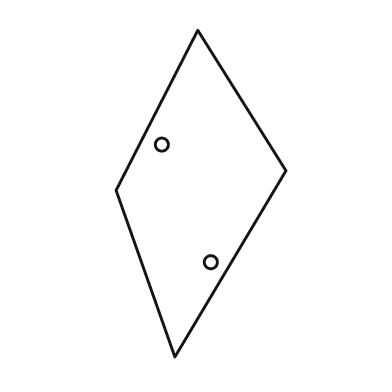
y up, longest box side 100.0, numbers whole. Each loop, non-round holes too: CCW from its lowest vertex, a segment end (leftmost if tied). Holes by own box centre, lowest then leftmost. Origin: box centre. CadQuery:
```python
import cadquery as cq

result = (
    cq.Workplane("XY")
    .moveTo(-8.0, -50.0)
    .lineTo(26.0, 7.0)
    .lineTo(-1.0, 50.0)
    .lineTo(-26.0, 1.0)
    .close()
    .moveTo(3.0, -21.0)
    .circle(2.0)
    .moveTo(-12.0, 15.0)
    .circle(2.0)
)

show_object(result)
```